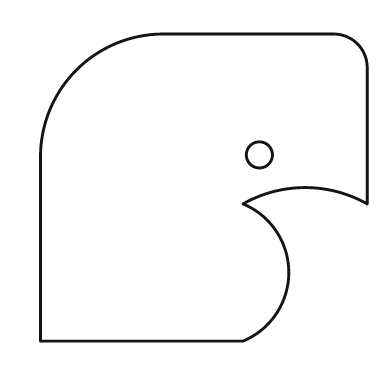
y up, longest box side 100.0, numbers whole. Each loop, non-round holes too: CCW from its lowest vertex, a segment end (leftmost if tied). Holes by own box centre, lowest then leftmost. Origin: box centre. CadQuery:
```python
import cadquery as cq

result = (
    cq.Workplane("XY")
    .moveTo(-50.0, -47.0)
    .lineTo(12.0, -47.0)
    .threePointArc((26.0, -26.0), (12.0, -5.0))
    .threePointArc((31.0, 0.0), (50.0, -5.0))
    .lineTo(50.0, 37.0)
    .threePointArc((47.0, 44.0), (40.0, 47.0))
    .lineTo(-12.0, 47.0)
    .threePointArc((-39.0, 36.0), (-50.0, 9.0))
    .close()
    .moveTo(17.0, 10.0)
    .circle(4.0)
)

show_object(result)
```